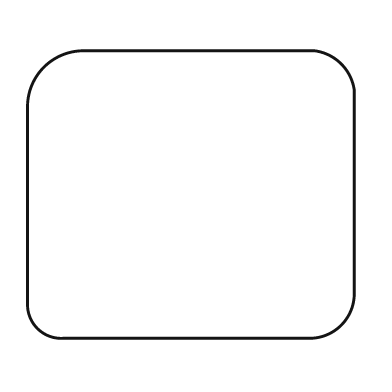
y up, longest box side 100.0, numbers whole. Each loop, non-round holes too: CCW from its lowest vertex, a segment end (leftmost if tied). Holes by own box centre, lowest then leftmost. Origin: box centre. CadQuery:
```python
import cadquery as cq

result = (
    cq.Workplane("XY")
    .moveTo(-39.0, -44.0)
    .lineTo(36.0, -44.0)
    .threePointArc((46.0, -40.0), (50.0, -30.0))
    .lineTo(50.0, 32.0)
    .threePointArc((46.0, 40.0), (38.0, 44.0))
    .lineTo(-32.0, 44.0)
    .threePointArc((-45.0, 39.0), (-50.0, 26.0))
    .lineTo(-50.0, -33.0)
    .threePointArc((-47.0, -41.0), (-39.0, -44.0))
    .close()
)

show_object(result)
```